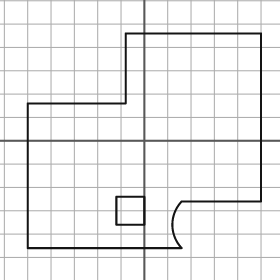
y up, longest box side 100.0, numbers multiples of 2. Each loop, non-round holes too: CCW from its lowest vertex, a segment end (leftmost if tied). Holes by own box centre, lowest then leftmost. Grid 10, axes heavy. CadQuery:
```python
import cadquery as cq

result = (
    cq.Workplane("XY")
    .moveTo(-50.0, -46.0)
    .lineTo(16.0, -46.0)
    .threePointArc((12.0, -36.0), (16.0, -26.0))
    .lineTo(50.0, -26.0)
    .lineTo(50.0, 46.0)
    .lineTo(-8.0, 46.0)
    .lineTo(-8.0, 16.0)
    .lineTo(-50.0, 16.0)
    .close()
    .moveTo(-12.0, -36.0)
    .lineTo(0.0, -36.0)
    .lineTo(0.0, -24.0)
    .lineTo(-12.0, -24.0)
    .close()
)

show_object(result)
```